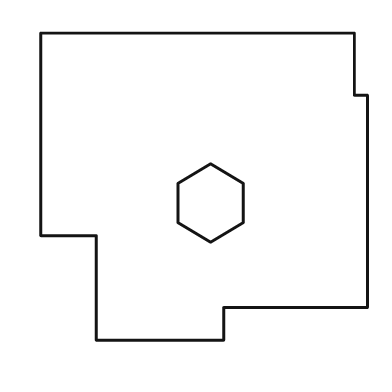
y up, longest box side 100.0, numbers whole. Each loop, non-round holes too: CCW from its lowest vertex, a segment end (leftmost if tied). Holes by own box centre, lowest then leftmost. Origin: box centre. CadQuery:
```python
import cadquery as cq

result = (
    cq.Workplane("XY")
    .moveTo(-33.0, -47.0)
    .lineTo(6.0, -47.0)
    .lineTo(6.0, -37.0)
    .lineTo(50.0, -37.0)
    .lineTo(50.0, 28.0)
    .lineTo(46.0, 28.0)
    .lineTo(46.0, 47.0)
    .lineTo(-50.0, 47.0)
    .lineTo(-50.0, -15.0)
    .lineTo(-33.0, -15.0)
    .close()
    .moveTo(2.0, -17.0)
    .lineTo(12.0, -11.0)
    .lineTo(12.0, 1.0)
    .lineTo(2.0, 7.0)
    .lineTo(-8.0, 1.0)
    .lineTo(-8.0, -11.0)
    .close()
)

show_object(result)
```